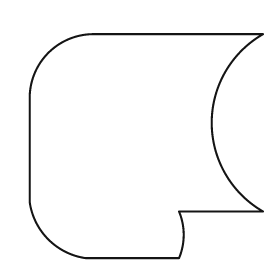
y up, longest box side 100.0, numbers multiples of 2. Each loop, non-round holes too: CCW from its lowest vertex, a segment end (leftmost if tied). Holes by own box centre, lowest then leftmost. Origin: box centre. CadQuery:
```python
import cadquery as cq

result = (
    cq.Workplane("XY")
    .moveTo(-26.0, -48.0)
    .lineTo(14.0, -48.0)
    .threePointArc((16.0, -38.0), (14.0, -28.0))
    .lineTo(50.0, -28.0)
    .threePointArc((28.0, 10.0), (50.0, 48.0))
    .lineTo(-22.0, 48.0)
    .threePointArc((-42.0, 40.0), (-50.0, 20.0))
    .lineTo(-50.0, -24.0)
    .threePointArc((-42.0, -40.0), (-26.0, -48.0))
    .close()
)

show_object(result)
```